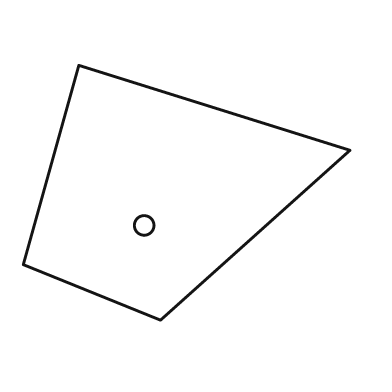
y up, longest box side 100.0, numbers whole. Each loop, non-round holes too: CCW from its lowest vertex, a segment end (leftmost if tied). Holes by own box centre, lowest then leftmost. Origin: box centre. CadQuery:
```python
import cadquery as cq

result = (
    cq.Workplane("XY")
    .moveTo(-8.0, -39.0)
    .lineTo(50.0, 13.0)
    .lineTo(-33.0, 39.0)
    .lineTo(-50.0, -22.0)
    .close()
    .moveTo(-13.0, -10.0)
    .circle(3.0)
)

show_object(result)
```